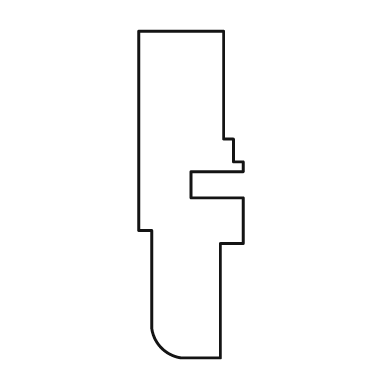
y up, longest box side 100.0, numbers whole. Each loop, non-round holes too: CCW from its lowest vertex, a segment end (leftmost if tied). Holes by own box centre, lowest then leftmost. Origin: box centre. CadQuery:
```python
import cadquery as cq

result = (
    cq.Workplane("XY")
    .moveTo(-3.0, -50.0)
    .lineTo(9.0, -50.0)
    .lineTo(9.0, -15.0)
    .lineTo(16.0, -15.0)
    .lineTo(16.0, -1.0)
    .lineTo(0.0, -1.0)
    .lineTo(0.0, 7.0)
    .lineTo(16.0, 7.0)
    .lineTo(16.0, 10.0)
    .lineTo(13.0, 10.0)
    .lineTo(13.0, 17.0)
    .lineTo(10.0, 17.0)
    .lineTo(10.0, 50.0)
    .lineTo(-16.0, 50.0)
    .lineTo(-16.0, -11.0)
    .lineTo(-12.0, -11.0)
    .lineTo(-12.0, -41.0)
    .threePointArc((-9.0, -47.0), (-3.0, -50.0))
    .close()
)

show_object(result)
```